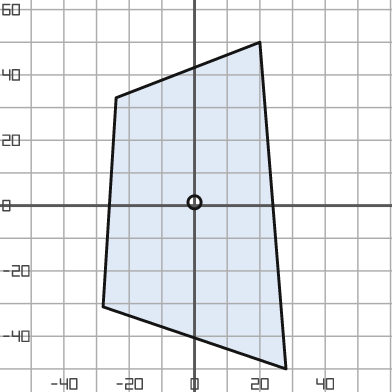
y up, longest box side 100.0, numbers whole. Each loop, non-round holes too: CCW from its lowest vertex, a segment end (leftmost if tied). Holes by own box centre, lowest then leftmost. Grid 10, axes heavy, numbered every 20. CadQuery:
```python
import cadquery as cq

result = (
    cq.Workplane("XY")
    .moveTo(28.0, -50.0)
    .lineTo(20.0, 50.0)
    .lineTo(-24.0, 33.0)
    .lineTo(-28.0, -31.0)
    .close()
    .moveTo(0.0, 1.0)
    .circle(2.0)
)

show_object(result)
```